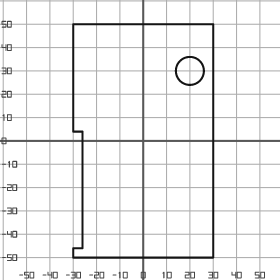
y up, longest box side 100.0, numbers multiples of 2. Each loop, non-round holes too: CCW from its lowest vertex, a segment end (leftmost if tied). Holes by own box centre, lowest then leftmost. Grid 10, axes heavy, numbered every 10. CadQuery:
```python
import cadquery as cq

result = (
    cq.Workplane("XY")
    .moveTo(-30.0, -50.0)
    .lineTo(30.0, -50.0)
    .lineTo(30.0, 50.0)
    .lineTo(-30.0, 50.0)
    .lineTo(-30.0, 4.0)
    .lineTo(-26.0, 4.0)
    .lineTo(-26.0, -46.0)
    .lineTo(-30.0, -46.0)
    .close()
    .moveTo(20.0, 30.0)
    .circle(6.0)
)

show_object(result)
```